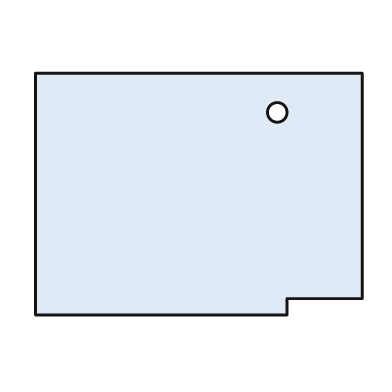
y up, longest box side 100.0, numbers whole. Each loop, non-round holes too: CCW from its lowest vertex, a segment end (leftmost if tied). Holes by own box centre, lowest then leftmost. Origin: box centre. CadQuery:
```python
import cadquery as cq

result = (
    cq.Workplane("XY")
    .moveTo(-50.0, -37.0)
    .lineTo(27.0, -37.0)
    .lineTo(27.0, -32.0)
    .lineTo(50.0, -32.0)
    .lineTo(50.0, 37.0)
    .lineTo(-50.0, 37.0)
    .close()
    .moveTo(24.0, 25.0)
    .circle(3.0)
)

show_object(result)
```